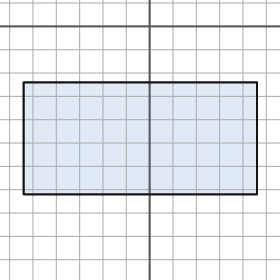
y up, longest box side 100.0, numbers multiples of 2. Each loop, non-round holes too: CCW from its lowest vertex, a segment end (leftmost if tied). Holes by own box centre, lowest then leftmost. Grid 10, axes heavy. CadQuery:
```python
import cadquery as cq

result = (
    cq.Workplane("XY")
    .moveTo(-54.0, -72.0)
    .lineTo(46.0, -72.0)
    .lineTo(46.0, -24.0)
    .lineTo(-54.0, -24.0)
    .close()
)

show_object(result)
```